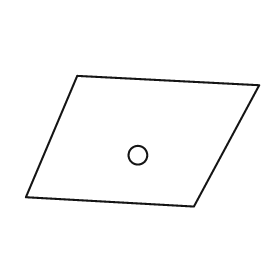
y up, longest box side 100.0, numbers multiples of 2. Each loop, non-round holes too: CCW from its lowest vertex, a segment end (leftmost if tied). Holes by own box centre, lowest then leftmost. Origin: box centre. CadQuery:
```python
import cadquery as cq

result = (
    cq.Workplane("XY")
    .moveTo(22.0, -28.0)
    .lineTo(50.0, 24.0)
    .lineTo(-28.0, 28.0)
    .lineTo(-50.0, -24.0)
    .close()
    .moveTo(-2.0, -6.0)
    .circle(4.0)
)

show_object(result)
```